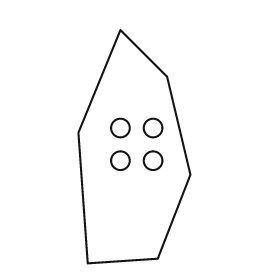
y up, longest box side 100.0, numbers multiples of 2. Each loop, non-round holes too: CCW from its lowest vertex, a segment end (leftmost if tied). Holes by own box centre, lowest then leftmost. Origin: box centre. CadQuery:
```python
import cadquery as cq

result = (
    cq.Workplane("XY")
    .moveTo(-20.0, -50.0)
    .lineTo(10.0, -48.0)
    .lineTo(24.0, -12.0)
    .lineTo(14.0, 30.0)
    .lineTo(-6.0, 50.0)
    .lineTo(-24.0, 6.0)
    .close()
    .moveTo(-6.0, -6.0)
    .circle(4.0)
    .moveTo(8.0, -6.0)
    .circle(4.0)
    .moveTo(-6.0, 8.0)
    .circle(4.0)
    .moveTo(8.0, 8.0)
    .circle(4.0)
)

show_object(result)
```